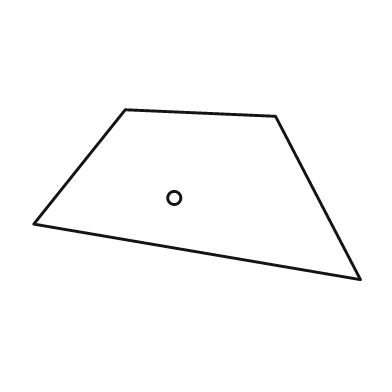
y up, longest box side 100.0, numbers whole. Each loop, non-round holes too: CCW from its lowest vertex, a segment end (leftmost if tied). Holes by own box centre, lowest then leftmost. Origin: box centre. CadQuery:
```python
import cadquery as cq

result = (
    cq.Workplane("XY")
    .moveTo(50.0, -26.0)
    .lineTo(24.0, 24.0)
    .lineTo(-22.0, 26.0)
    .lineTo(-50.0, -9.0)
    .close()
    .moveTo(-7.0, -1.0)
    .circle(2.0)
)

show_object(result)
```